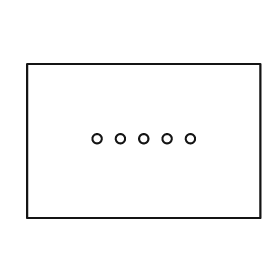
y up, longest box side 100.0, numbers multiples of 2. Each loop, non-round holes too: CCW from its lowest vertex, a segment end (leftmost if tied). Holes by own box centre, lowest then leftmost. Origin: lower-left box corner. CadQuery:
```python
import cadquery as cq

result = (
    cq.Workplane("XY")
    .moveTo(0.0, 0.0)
    .lineTo(100.0, 0.0)
    .lineTo(100.0, 66.0)
    .lineTo(0.0, 66.0)
    .close()
    .moveTo(30.0, 34.0)
    .circle(2.0)
    .moveTo(40.0, 34.0)
    .circle(2.0)
    .moveTo(50.0, 34.0)
    .circle(2.0)
    .moveTo(60.0, 34.0)
    .circle(2.0)
    .moveTo(70.0, 34.0)
    .circle(2.0)
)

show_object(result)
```